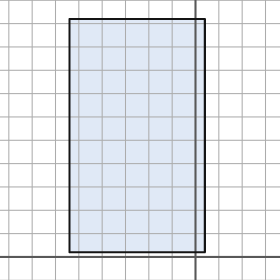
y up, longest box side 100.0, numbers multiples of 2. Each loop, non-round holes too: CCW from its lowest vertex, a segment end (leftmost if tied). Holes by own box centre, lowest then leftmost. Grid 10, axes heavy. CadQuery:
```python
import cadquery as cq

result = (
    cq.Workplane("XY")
    .moveTo(-54.0, 2.0)
    .lineTo(4.0, 2.0)
    .lineTo(4.0, 102.0)
    .lineTo(-54.0, 102.0)
    .close()
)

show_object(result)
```